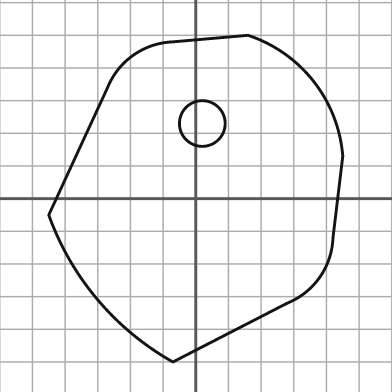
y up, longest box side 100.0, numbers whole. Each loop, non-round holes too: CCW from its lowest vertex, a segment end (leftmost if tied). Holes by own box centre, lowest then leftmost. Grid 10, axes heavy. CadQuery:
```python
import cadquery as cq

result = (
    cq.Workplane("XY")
    .moveTo(-7.0, -50.0)
    .lineTo(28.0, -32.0)
    .threePointArc((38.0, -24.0), (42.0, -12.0))
    .lineTo(45.0, 13.0)
    .threePointArc((36.0, 36.0), (16.0, 50.0))
    .lineTo(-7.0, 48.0)
    .threePointArc((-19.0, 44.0), (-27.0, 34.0))
    .lineTo(-45.0, -5.0)
    .threePointArc((-30.0, -31.0), (-7.0, -50.0))
    .close()
    .moveTo(2.0, 23.0)
    .circle(7.0)
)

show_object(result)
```